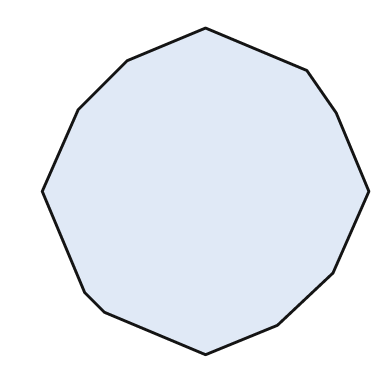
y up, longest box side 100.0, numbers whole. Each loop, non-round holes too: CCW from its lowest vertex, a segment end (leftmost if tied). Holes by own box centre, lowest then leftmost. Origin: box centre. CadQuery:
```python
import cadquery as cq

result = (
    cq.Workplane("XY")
    .moveTo(0.0, -50.0)
    .lineTo(22.0, -41.0)
    .lineTo(39.0, -25.0)
    .lineTo(50.0, 0.0)
    .lineTo(40.0, 24.0)
    .lineTo(31.0, 37.0)
    .lineTo(0.0, 50.0)
    .lineTo(-24.0, 40.0)
    .lineTo(-39.0, 25.0)
    .lineTo(-50.0, 0.0)
    .lineTo(-37.0, -31.0)
    .lineTo(-31.0, -37.0)
    .close()
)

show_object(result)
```